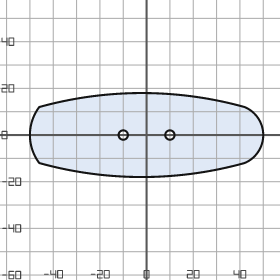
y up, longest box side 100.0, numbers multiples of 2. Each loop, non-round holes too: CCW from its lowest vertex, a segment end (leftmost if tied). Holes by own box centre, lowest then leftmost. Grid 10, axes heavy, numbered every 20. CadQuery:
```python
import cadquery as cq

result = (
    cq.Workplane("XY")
    .moveTo(-46.0, -12.0)
    .threePointArc((-2.0, -18.0), (42.0, -12.0))
    .threePointArc((50.0, 0.0), (42.0, 12.0))
    .threePointArc((-2.0, 18.0), (-46.0, 12.0))
    .threePointArc((-50.0, 0.0), (-46.0, -12.0))
    .close()
    .moveTo(-10.0, 0.0)
    .circle(2.0)
    .moveTo(10.0, 0.0)
    .circle(2.0)
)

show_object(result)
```